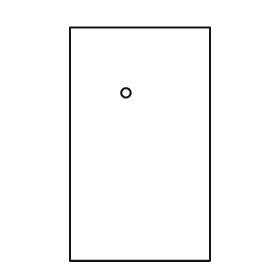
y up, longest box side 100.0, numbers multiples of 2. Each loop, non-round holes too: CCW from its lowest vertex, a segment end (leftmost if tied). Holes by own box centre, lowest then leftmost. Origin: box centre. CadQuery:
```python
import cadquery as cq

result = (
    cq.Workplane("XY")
    .moveTo(-30.0, -50.0)
    .lineTo(30.0, -50.0)
    .lineTo(30.0, 50.0)
    .lineTo(-30.0, 50.0)
    .close()
    .moveTo(-6.0, 22.0)
    .circle(2.0)
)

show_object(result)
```